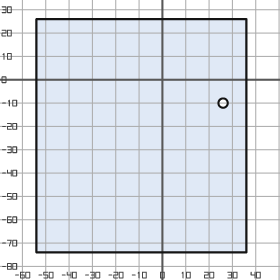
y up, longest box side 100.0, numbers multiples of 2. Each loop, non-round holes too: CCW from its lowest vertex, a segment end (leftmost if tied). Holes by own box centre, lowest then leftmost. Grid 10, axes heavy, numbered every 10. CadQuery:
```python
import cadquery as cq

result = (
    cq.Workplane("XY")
    .moveTo(-54.0, -74.0)
    .lineTo(36.0, -74.0)
    .lineTo(36.0, 26.0)
    .lineTo(-54.0, 26.0)
    .close()
    .moveTo(26.0, -10.0)
    .circle(2.0)
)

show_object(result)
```